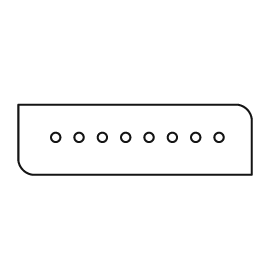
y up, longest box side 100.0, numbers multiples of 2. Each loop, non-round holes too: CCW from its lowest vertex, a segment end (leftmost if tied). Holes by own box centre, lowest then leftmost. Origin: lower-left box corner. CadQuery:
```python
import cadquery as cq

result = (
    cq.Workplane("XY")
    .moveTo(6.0, 0.0)
    .lineTo(100.0, 0.0)
    .lineTo(100.0, 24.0)
    .threePointArc((98.0, 28.0), (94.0, 30.0))
    .lineTo(0.0, 30.0)
    .lineTo(0.0, 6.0)
    .threePointArc((2.0, 2.0), (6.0, 0.0))
    .close()
    .moveTo(16.0, 16.0)
    .circle(2.0)
    .moveTo(26.0, 16.0)
    .circle(2.0)
    .moveTo(36.0, 16.0)
    .circle(2.0)
    .moveTo(46.0, 16.0)
    .circle(2.0)
    .moveTo(56.0, 16.0)
    .circle(2.0)
    .moveTo(66.0, 16.0)
    .circle(2.0)
    .moveTo(76.0, 16.0)
    .circle(2.0)
    .moveTo(86.0, 16.0)
    .circle(2.0)
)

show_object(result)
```